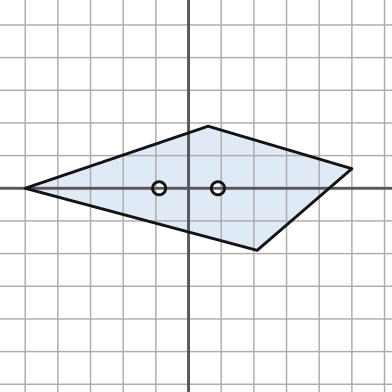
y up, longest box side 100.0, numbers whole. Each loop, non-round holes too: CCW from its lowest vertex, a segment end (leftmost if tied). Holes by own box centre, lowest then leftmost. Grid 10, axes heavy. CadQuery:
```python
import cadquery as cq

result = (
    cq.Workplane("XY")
    .moveTo(21.0, -19.0)
    .lineTo(50.0, 6.0)
    .lineTo(6.0, 19.0)
    .lineTo(-50.0, 0.0)
    .close()
    .moveTo(-9.0, 0.0)
    .circle(2.0)
    .moveTo(9.0, 0.0)
    .circle(2.0)
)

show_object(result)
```